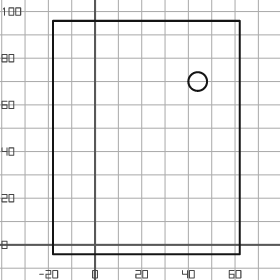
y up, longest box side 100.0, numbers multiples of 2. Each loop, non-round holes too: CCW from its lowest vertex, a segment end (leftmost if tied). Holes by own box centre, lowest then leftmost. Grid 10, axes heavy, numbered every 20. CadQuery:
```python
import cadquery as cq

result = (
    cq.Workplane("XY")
    .moveTo(-18.0, -4.0)
    .lineTo(62.0, -4.0)
    .lineTo(62.0, 96.0)
    .lineTo(-18.0, 96.0)
    .close()
    .moveTo(44.0, 70.0)
    .circle(4.0)
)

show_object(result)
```